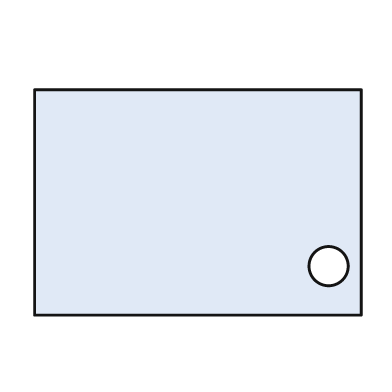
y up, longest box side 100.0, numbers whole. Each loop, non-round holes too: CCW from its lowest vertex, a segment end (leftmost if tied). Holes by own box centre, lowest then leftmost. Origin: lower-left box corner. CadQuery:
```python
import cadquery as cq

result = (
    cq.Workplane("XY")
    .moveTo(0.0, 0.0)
    .lineTo(100.0, 0.0)
    .lineTo(100.0, 69.0)
    .lineTo(0.0, 69.0)
    .close()
    .moveTo(90.0, 15.0)
    .circle(6.0)
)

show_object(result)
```